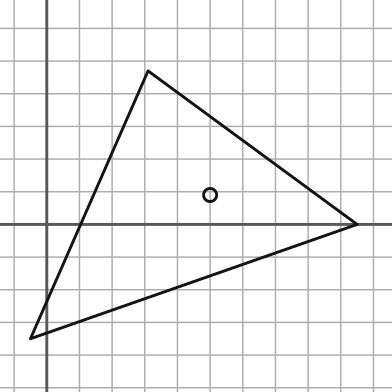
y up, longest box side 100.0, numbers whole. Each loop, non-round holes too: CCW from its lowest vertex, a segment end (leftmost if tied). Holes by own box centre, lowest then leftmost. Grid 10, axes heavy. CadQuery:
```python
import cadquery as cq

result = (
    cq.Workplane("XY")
    .moveTo(-5.0, -35.0)
    .lineTo(95.0, 0.0)
    .lineTo(31.0, 47.0)
    .close()
    .moveTo(50.0, 9.0)
    .circle(2.0)
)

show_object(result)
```